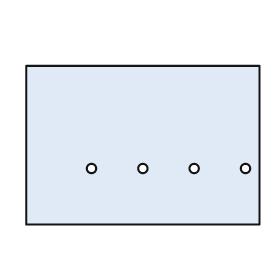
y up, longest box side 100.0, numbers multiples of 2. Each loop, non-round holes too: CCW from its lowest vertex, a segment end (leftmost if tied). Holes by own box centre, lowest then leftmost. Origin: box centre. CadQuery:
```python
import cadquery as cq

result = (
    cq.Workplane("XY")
    .moveTo(-50.0, -34.0)
    .lineTo(50.0, -34.0)
    .lineTo(50.0, 34.0)
    .lineTo(-50.0, 34.0)
    .close()
    .moveTo(-22.0, -10.0)
    .circle(2.0)
    .moveTo(0.0, -10.0)
    .circle(2.0)
    .moveTo(22.0, -10.0)
    .circle(2.0)
    .moveTo(44.0, -10.0)
    .circle(2.0)
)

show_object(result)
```